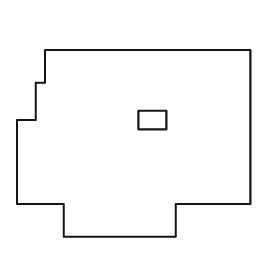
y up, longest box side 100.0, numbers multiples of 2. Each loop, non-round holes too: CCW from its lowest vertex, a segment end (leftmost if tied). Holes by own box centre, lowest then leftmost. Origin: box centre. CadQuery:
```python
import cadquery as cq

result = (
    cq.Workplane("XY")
    .moveTo(-30.0, -40.0)
    .lineTo(18.0, -40.0)
    .lineTo(18.0, -26.0)
    .lineTo(50.0, -26.0)
    .lineTo(50.0, 40.0)
    .lineTo(-38.0, 40.0)
    .lineTo(-38.0, 26.0)
    .lineTo(-42.0, 26.0)
    .lineTo(-42.0, 10.0)
    .lineTo(-50.0, 10.0)
    .lineTo(-50.0, -26.0)
    .lineTo(-30.0, -26.0)
    .close()
    .moveTo(2.0, 6.0)
    .lineTo(14.0, 6.0)
    .lineTo(14.0, 14.0)
    .lineTo(2.0, 14.0)
    .close()
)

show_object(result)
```